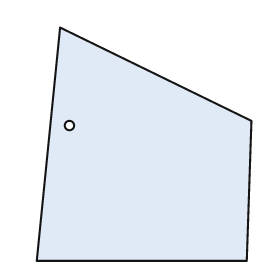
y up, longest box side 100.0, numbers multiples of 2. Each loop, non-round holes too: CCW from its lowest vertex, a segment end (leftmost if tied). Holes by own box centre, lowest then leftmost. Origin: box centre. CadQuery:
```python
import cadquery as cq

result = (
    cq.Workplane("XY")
    .moveTo(-46.0, -50.0)
    .lineTo(44.0, -50.0)
    .lineTo(46.0, 10.0)
    .lineTo(-36.0, 50.0)
    .close()
    .moveTo(-32.0, 8.0)
    .circle(2.0)
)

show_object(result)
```